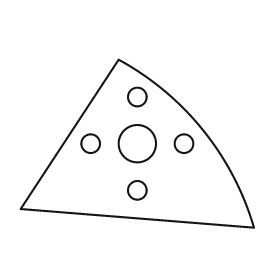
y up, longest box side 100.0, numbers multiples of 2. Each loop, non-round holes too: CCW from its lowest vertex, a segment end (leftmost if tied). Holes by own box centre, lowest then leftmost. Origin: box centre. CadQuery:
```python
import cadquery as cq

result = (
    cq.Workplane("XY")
    .moveTo(50.0, -36.0)
    .threePointArc((28.0, 6.0), (-8.0, 36.0))
    .lineTo(-50.0, -28.0)
    .close()
    .moveTo(0.0, -20.0)
    .circle(4.0)
    .moveTo(-20.0, 0.0)
    .circle(4.0)
    .moveTo(0.0, 0.0)
    .circle(8.0)
    .moveTo(20.0, 0.0)
    .circle(4.0)
    .moveTo(0.0, 20.0)
    .circle(4.0)
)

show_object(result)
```